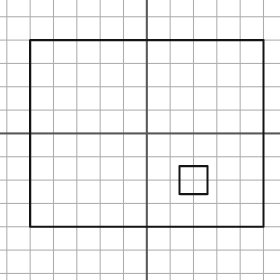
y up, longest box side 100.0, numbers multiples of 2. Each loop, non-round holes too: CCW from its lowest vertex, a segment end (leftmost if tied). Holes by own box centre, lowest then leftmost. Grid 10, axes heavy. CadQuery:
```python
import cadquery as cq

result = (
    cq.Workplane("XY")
    .moveTo(-50.0, -40.0)
    .lineTo(50.0, -40.0)
    .lineTo(50.0, 40.0)
    .lineTo(-50.0, 40.0)
    .close()
    .moveTo(14.0, -26.0)
    .lineTo(26.0, -26.0)
    .lineTo(26.0, -14.0)
    .lineTo(14.0, -14.0)
    .close()
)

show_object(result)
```